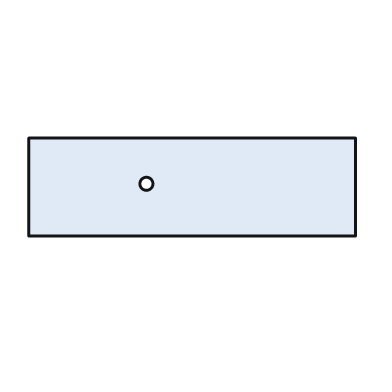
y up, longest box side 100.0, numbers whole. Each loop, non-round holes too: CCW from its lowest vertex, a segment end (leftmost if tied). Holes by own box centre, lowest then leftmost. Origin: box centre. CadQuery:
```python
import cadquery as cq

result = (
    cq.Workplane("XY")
    .moveTo(-50.0, -15.0)
    .lineTo(50.0, -15.0)
    .lineTo(50.0, 15.0)
    .lineTo(-50.0, 15.0)
    .close()
    .moveTo(-14.0, 1.0)
    .circle(2.0)
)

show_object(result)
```